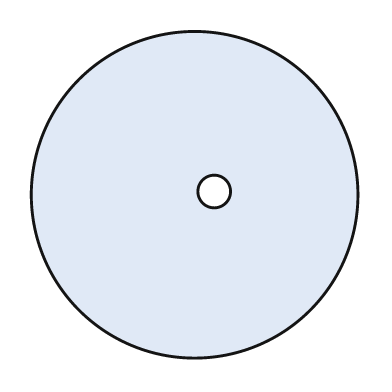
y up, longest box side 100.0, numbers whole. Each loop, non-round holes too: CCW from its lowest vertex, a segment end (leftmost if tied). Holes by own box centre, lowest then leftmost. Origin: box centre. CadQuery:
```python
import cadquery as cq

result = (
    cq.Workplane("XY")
    .moveTo(0.0, 0.0)
    .circle(50.0)
    .moveTo(6.0, 1.0)
    .circle(5.0)
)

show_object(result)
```